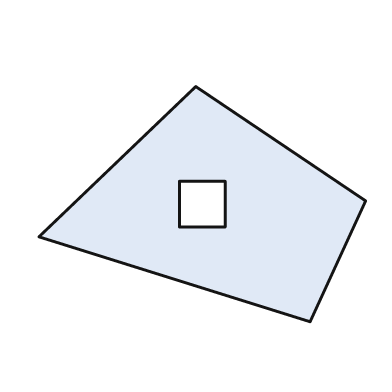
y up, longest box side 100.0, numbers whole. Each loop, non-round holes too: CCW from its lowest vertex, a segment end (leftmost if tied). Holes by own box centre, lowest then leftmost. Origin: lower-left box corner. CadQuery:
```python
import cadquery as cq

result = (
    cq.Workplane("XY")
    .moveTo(83.0, 0.0)
    .lineTo(100.0, 37.0)
    .lineTo(48.0, 72.0)
    .lineTo(0.0, 26.0)
    .close()
    .moveTo(43.0, 29.0)
    .lineTo(57.0, 29.0)
    .lineTo(57.0, 43.0)
    .lineTo(43.0, 43.0)
    .close()
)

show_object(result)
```